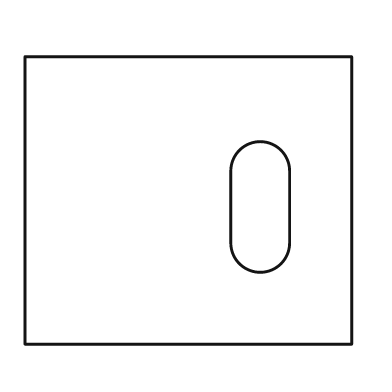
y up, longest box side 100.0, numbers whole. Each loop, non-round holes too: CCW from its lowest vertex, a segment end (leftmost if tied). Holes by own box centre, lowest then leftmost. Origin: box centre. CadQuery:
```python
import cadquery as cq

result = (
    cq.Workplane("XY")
    .moveTo(-50.0, -44.0)
    .lineTo(50.0, -44.0)
    .lineTo(50.0, 44.0)
    .lineTo(-50.0, 44.0)
    .close()
    .moveTo(13.0, -13.0)
    .threePointArc((22.0, -22.0), (31.0, -13.0))
    .lineTo(31.0, 9.0)
    .threePointArc((22.0, 18.0), (13.0, 9.0))
    .close()
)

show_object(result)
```